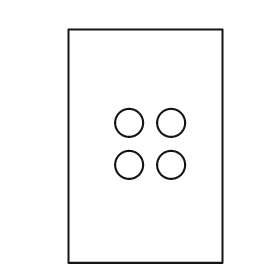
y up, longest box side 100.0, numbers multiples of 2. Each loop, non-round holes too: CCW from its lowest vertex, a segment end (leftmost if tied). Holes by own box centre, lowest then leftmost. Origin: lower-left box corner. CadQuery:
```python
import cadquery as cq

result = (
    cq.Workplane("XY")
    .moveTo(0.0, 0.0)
    .lineTo(66.0, 0.0)
    .lineTo(66.0, 100.0)
    .lineTo(0.0, 100.0)
    .close()
    .moveTo(26.0, 42.0)
    .circle(6.0)
    .moveTo(44.0, 42.0)
    .circle(6.0)
    .moveTo(26.0, 60.0)
    .circle(6.0)
    .moveTo(44.0, 60.0)
    .circle(6.0)
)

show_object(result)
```